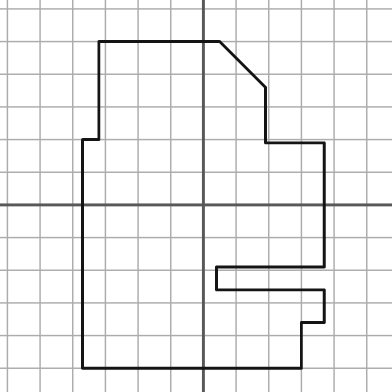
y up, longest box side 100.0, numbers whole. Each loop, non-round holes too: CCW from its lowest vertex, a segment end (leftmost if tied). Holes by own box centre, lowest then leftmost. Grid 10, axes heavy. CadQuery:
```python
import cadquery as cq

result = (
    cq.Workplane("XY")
    .moveTo(-37.0, -50.0)
    .lineTo(30.0, -50.0)
    .lineTo(30.0, -36.0)
    .lineTo(37.0, -36.0)
    .lineTo(37.0, -26.0)
    .lineTo(4.0, -26.0)
    .lineTo(4.0, -19.0)
    .lineTo(37.0, -19.0)
    .lineTo(37.0, 19.0)
    .lineTo(19.0, 19.0)
    .lineTo(19.0, 36.0)
    .lineTo(5.0, 50.0)
    .lineTo(-32.0, 50.0)
    .lineTo(-32.0, 20.0)
    .lineTo(-37.0, 20.0)
    .close()
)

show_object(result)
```